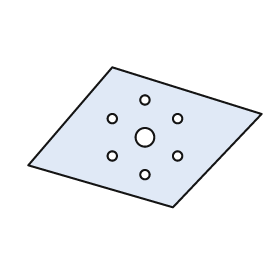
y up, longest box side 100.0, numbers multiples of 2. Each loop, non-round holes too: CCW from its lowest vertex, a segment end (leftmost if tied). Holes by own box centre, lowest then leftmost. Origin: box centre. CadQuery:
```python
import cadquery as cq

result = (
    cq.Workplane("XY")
    .moveTo(12.0, -30.0)
    .lineTo(50.0, 10.0)
    .lineTo(-14.0, 30.0)
    .lineTo(-50.0, -12.0)
    .close()
    .moveTo(0.0, -16.0)
    .circle(2.0)
    .moveTo(-14.0, -8.0)
    .circle(2.0)
    .moveTo(14.0, -8.0)
    .circle(2.0)
    .moveTo(0.0, 0.0)
    .circle(4.0)
    .moveTo(-14.0, 8.0)
    .circle(2.0)
    .moveTo(14.0, 8.0)
    .circle(2.0)
    .moveTo(0.0, 16.0)
    .circle(2.0)
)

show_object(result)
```